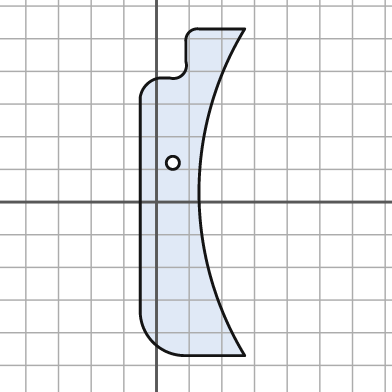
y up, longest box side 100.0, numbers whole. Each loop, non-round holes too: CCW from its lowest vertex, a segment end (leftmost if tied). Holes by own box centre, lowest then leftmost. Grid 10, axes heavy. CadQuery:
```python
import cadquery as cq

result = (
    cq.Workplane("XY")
    .moveTo(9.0, -47.0)
    .lineTo(27.0, -47.0)
    .threePointArc((13.0, 3.0), (27.0, 53.0))
    .lineTo(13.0, 53.0)
    .threePointArc((10.0, 52.0), (9.0, 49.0))
    .lineTo(9.0, 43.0)
    .threePointArc((8.0, 39.0), (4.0, 38.0))
    .lineTo(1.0, 38.0)
    .threePointArc((-3.0, 36.0), (-5.0, 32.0))
    .lineTo(-5.0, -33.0)
    .threePointArc((-1.0, -43.0), (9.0, -47.0))
    .close()
    .moveTo(5.0, 12.0)
    .circle(2.0)
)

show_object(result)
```